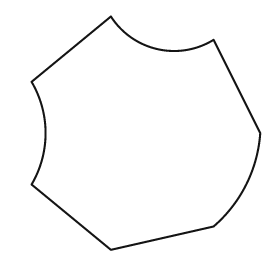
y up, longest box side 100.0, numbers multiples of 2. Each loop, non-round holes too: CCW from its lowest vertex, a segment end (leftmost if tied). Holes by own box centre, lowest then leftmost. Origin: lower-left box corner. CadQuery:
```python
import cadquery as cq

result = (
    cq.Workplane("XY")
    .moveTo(34.0, 0.0)
    .lineTo(78.0, 10.0)
    .threePointArc((92.0, 28.0), (98.0, 50.0))
    .lineTo(78.0, 90.0)
    .threePointArc((54.0, 86.0), (34.0, 100.0))
    .lineTo(0.0, 72.0)
    .threePointArc((6.0, 50.0), (0.0, 28.0))
    .close()
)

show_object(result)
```